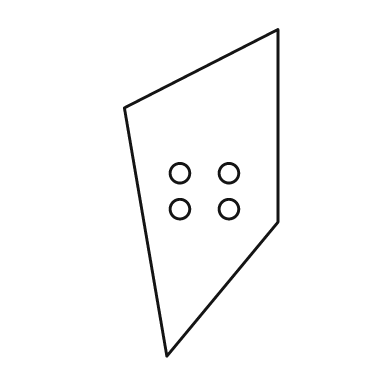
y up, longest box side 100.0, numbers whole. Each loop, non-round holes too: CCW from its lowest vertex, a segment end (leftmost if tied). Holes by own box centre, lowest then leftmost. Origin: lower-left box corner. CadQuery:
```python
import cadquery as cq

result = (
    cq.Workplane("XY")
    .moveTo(13.0, 0.0)
    .lineTo(47.0, 41.0)
    .lineTo(47.0, 100.0)
    .lineTo(0.0, 76.0)
    .close()
    .moveTo(17.0, 45.0)
    .circle(3.0)
    .moveTo(32.0, 45.0)
    .circle(3.0)
    .moveTo(17.0, 56.0)
    .circle(3.0)
    .moveTo(32.0, 56.0)
    .circle(3.0)
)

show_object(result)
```